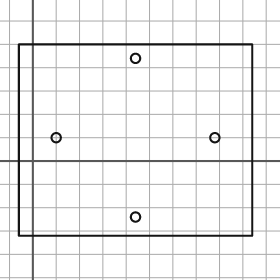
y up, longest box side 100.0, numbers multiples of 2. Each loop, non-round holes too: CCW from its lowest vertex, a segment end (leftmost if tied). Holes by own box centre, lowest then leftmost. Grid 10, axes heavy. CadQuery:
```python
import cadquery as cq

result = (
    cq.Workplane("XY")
    .moveTo(-6.0, -32.0)
    .lineTo(94.0, -32.0)
    .lineTo(94.0, 50.0)
    .lineTo(-6.0, 50.0)
    .close()
    .moveTo(44.0, -24.0)
    .circle(2.0)
    .moveTo(10.0, 10.0)
    .circle(2.0)
    .moveTo(78.0, 10.0)
    .circle(2.0)
    .moveTo(44.0, 44.0)
    .circle(2.0)
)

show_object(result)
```